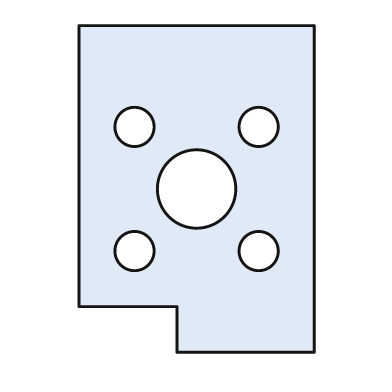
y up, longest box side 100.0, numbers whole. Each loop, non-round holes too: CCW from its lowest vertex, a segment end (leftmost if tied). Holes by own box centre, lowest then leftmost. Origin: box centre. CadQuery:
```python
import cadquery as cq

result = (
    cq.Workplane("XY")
    .moveTo(-6.0, -50.0)
    .lineTo(36.0, -50.0)
    .lineTo(36.0, 50.0)
    .lineTo(-36.0, 50.0)
    .lineTo(-36.0, -36.0)
    .lineTo(-6.0, -36.0)
    .close()
    .moveTo(-19.0, -19.0)
    .circle(6.0)
    .moveTo(19.0, -19.0)
    .circle(6.0)
    .moveTo(0.0, 0.0)
    .circle(12.0)
    .moveTo(-19.0, 19.0)
    .circle(6.0)
    .moveTo(19.0, 19.0)
    .circle(6.0)
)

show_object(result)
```